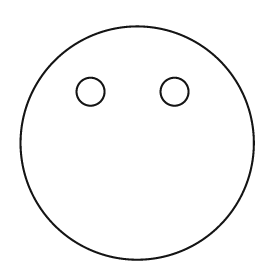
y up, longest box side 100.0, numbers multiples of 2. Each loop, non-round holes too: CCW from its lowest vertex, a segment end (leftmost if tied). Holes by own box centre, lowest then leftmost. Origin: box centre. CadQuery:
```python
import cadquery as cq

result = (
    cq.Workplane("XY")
    .moveTo(0.0, 0.0)
    .circle(50.0)
    .moveTo(-20.0, 22.0)
    .circle(6.0)
    .moveTo(16.0, 22.0)
    .circle(6.0)
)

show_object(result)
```